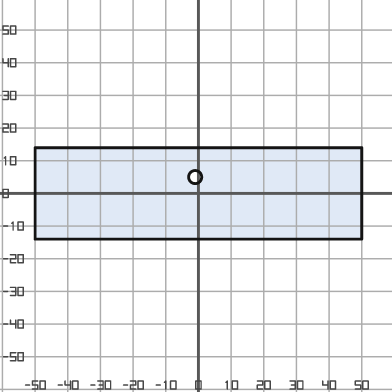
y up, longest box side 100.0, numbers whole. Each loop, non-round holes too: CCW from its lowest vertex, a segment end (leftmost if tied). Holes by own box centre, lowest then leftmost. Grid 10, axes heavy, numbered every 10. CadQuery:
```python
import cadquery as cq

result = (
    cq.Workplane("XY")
    .moveTo(-50.0, -14.0)
    .lineTo(50.0, -14.0)
    .lineTo(50.0, 14.0)
    .lineTo(-50.0, 14.0)
    .close()
    .moveTo(-1.0, 5.0)
    .circle(2.0)
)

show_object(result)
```